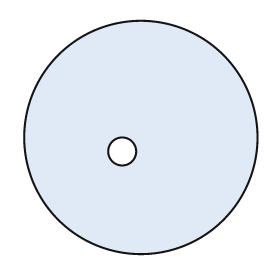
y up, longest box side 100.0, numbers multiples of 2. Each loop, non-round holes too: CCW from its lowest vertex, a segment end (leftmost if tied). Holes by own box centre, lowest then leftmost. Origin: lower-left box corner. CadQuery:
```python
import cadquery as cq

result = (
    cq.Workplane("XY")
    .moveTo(50.0, 50.0)
    .circle(50.0)
    .moveTo(42.0, 44.0)
    .circle(6.0)
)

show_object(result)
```